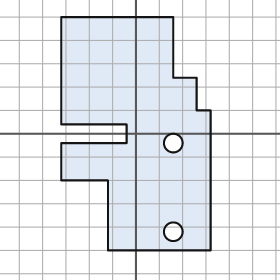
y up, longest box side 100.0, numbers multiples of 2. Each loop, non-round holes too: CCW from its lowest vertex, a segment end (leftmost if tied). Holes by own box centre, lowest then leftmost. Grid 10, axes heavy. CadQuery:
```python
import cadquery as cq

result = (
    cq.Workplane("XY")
    .moveTo(-12.0, -50.0)
    .lineTo(32.0, -50.0)
    .lineTo(32.0, 10.0)
    .lineTo(26.0, 10.0)
    .lineTo(26.0, 24.0)
    .lineTo(16.0, 24.0)
    .lineTo(16.0, 50.0)
    .lineTo(-32.0, 50.0)
    .lineTo(-32.0, 4.0)
    .lineTo(-4.0, 4.0)
    .lineTo(-4.0, -4.0)
    .lineTo(-32.0, -4.0)
    .lineTo(-32.0, -20.0)
    .lineTo(-12.0, -20.0)
    .close()
    .moveTo(16.0, -42.0)
    .circle(4.0)
    .moveTo(16.0, -4.0)
    .circle(4.0)
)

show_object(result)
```